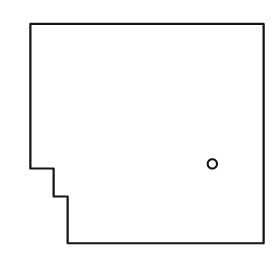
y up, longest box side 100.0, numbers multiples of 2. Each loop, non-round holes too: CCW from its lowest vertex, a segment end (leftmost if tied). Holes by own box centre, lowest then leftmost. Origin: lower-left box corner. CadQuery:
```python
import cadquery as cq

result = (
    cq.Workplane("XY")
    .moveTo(16.0, 0.0)
    .lineTo(100.0, 0.0)
    .lineTo(100.0, 94.0)
    .lineTo(0.0, 94.0)
    .lineTo(0.0, 32.0)
    .lineTo(10.0, 32.0)
    .lineTo(10.0, 20.0)
    .lineTo(16.0, 20.0)
    .close()
    .moveTo(78.0, 34.0)
    .circle(2.0)
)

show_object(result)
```